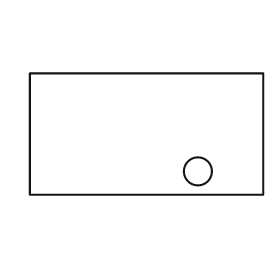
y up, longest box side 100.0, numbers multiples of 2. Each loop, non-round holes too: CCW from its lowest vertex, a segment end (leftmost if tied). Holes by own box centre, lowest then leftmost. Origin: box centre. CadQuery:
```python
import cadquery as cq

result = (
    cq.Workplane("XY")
    .moveTo(-50.0, -26.0)
    .lineTo(50.0, -26.0)
    .lineTo(50.0, 26.0)
    .lineTo(-50.0, 26.0)
    .close()
    .moveTo(22.0, -16.0)
    .circle(6.0)
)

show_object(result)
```